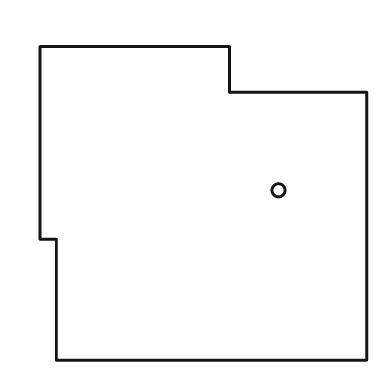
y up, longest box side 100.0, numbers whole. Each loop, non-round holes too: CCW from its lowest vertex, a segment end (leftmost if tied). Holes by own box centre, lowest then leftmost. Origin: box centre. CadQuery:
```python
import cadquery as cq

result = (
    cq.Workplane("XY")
    .moveTo(-45.0, -48.0)
    .lineTo(50.0, -48.0)
    .lineTo(50.0, 34.0)
    .lineTo(8.0, 34.0)
    .lineTo(8.0, 48.0)
    .lineTo(-50.0, 48.0)
    .lineTo(-50.0, -11.0)
    .lineTo(-45.0, -11.0)
    .close()
    .moveTo(23.0, 4.0)
    .circle(2.0)
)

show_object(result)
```